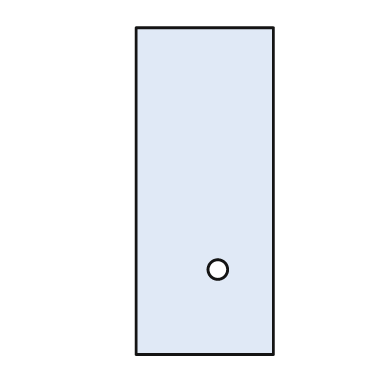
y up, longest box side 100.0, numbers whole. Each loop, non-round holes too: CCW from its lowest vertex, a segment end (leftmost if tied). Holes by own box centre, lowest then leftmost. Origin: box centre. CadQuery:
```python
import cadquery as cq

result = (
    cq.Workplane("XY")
    .moveTo(-21.0, -50.0)
    .lineTo(21.0, -50.0)
    .lineTo(21.0, 50.0)
    .lineTo(-21.0, 50.0)
    .close()
    .moveTo(4.0, -24.0)
    .circle(3.0)
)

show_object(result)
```